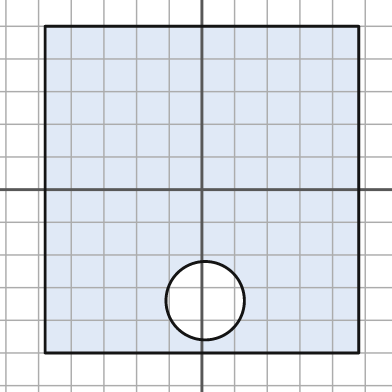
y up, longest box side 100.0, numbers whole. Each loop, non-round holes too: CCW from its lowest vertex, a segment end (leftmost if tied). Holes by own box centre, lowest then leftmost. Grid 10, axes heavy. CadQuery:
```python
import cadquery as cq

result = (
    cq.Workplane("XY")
    .moveTo(-48.0, -50.0)
    .lineTo(48.0, -50.0)
    .lineTo(48.0, 50.0)
    .lineTo(-48.0, 50.0)
    .close()
    .moveTo(1.0, -34.0)
    .circle(12.0)
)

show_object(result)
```